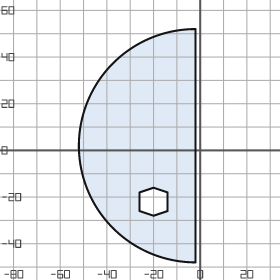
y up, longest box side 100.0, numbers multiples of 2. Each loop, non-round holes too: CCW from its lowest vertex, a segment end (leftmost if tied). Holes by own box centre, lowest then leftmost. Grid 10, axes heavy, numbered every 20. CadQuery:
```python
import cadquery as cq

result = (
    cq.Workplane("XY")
    .moveTo(-2.0, -48.0)
    .lineTo(-2.0, 52.0)
    .threePointArc((-52.0, 2.0), (-2.0, -48.0))
    .close()
    .moveTo(-20.0, -28.0)
    .lineTo(-14.0, -26.0)
    .lineTo(-14.0, -18.0)
    .lineTo(-20.0, -16.0)
    .lineTo(-26.0, -18.0)
    .lineTo(-26.0, -26.0)
    .close()
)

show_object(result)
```